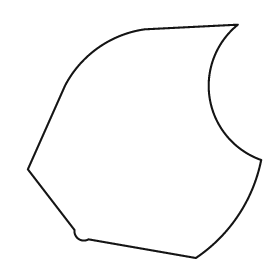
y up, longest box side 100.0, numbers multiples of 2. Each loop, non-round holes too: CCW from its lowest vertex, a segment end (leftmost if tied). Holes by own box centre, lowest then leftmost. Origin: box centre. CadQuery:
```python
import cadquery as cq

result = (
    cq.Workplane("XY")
    .moveTo(22.0, -50.0)
    .threePointArc((40.0, -32.0), (50.0, -8.0))
    .threePointArc((28.0, 18.0), (40.0, 50.0))
    .lineTo(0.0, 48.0)
    .threePointArc((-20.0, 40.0), (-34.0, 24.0))
    .lineTo(-50.0, -12.0)
    .lineTo(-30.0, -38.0)
    .threePointArc((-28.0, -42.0), (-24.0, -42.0))
    .close()
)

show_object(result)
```